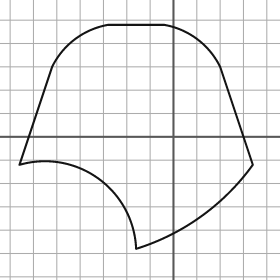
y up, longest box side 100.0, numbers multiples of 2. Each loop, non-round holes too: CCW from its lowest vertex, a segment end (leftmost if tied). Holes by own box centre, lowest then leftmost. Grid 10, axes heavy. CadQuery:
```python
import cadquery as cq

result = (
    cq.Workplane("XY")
    .moveTo(-16.0, -48.0)
    .threePointArc((12.0, -34.0), (34.0, -12.0))
    .lineTo(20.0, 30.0)
    .threePointArc((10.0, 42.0), (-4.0, 48.0))
    .lineTo(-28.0, 48.0)
    .threePointArc((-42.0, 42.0), (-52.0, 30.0))
    .lineTo(-66.0, -12.0)
    .threePointArc((-32.0, -18.0), (-16.0, -48.0))
    .close()
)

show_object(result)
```